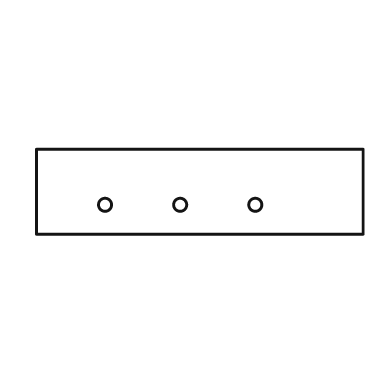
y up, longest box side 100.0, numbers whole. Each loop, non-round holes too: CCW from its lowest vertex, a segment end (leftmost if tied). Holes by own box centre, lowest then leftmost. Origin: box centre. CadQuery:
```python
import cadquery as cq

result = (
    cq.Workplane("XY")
    .moveTo(-50.0, -13.0)
    .lineTo(50.0, -13.0)
    .lineTo(50.0, 13.0)
    .lineTo(-50.0, 13.0)
    .close()
    .moveTo(-29.0, -4.0)
    .circle(2.0)
    .moveTo(-6.0, -4.0)
    .circle(2.0)
    .moveTo(17.0, -4.0)
    .circle(2.0)
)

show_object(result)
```